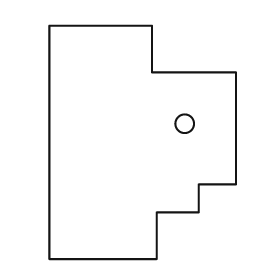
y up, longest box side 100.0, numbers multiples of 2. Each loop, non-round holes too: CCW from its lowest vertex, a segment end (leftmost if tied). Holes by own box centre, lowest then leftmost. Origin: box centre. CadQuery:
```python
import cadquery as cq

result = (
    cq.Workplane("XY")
    .moveTo(-40.0, -50.0)
    .lineTo(6.0, -50.0)
    .lineTo(6.0, -30.0)
    .lineTo(24.0, -30.0)
    .lineTo(24.0, -18.0)
    .lineTo(40.0, -18.0)
    .lineTo(40.0, 30.0)
    .lineTo(4.0, 30.0)
    .lineTo(4.0, 50.0)
    .lineTo(-40.0, 50.0)
    .close()
    .moveTo(18.0, 8.0)
    .circle(4.0)
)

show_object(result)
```